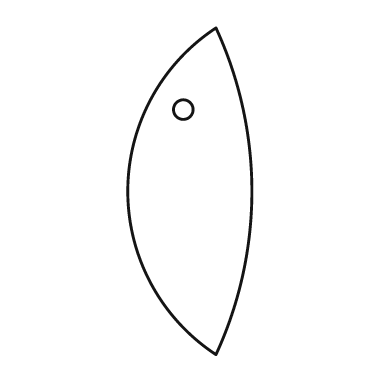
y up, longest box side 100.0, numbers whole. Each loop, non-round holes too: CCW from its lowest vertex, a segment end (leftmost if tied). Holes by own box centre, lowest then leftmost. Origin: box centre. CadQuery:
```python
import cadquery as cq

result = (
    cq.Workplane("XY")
    .moveTo(8.0, -50.0)
    .threePointArc((19.0, 0.0), (8.0, 50.0))
    .threePointArc((-19.0, 0.0), (8.0, -50.0))
    .close()
    .moveTo(-2.0, 25.0)
    .circle(3.0)
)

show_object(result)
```